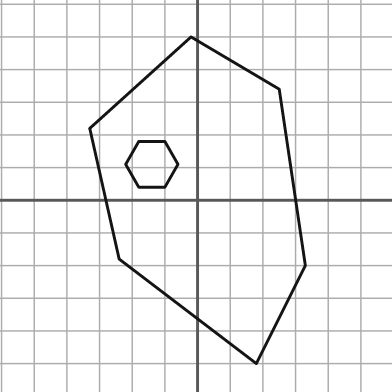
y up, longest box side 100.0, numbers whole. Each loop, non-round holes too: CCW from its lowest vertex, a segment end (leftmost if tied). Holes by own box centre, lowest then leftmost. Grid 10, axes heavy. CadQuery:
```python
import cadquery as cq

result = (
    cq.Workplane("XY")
    .moveTo(18.0, -50.0)
    .lineTo(33.0, -20.0)
    .lineTo(25.0, 34.0)
    .lineTo(-2.0, 50.0)
    .lineTo(-33.0, 22.0)
    .lineTo(-24.0, -18.0)
    .close()
    .moveTo(-18.0, 4.0)
    .lineTo(-10.0, 4.0)
    .lineTo(-6.0, 11.0)
    .lineTo(-10.0, 18.0)
    .lineTo(-18.0, 18.0)
    .lineTo(-22.0, 11.0)
    .close()
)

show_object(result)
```